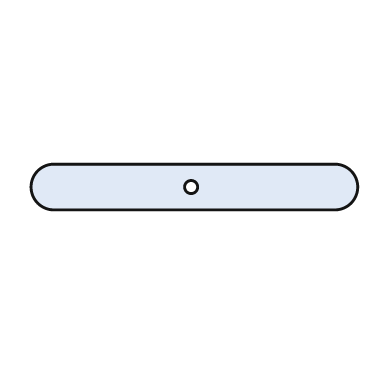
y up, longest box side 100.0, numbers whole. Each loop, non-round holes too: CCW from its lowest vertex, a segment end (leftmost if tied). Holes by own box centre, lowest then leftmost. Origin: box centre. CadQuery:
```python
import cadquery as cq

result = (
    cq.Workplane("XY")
    .moveTo(-43.0, -7.0)
    .lineTo(43.0, -7.0)
    .threePointArc((50.0, 0.0), (43.0, 7.0))
    .lineTo(-43.0, 7.0)
    .threePointArc((-50.0, 0.0), (-43.0, -7.0))
    .close()
    .moveTo(-1.0, 0.0)
    .circle(2.0)
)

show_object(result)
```